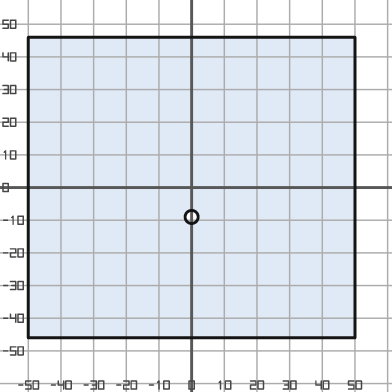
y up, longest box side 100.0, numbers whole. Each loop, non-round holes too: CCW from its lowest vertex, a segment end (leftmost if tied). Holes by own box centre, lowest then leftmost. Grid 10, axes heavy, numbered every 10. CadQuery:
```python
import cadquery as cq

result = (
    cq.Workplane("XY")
    .moveTo(-50.0, -46.0)
    .lineTo(50.0, -46.0)
    .lineTo(50.0, 46.0)
    .lineTo(-50.0, 46.0)
    .close()
    .moveTo(0.0, -9.0)
    .circle(2.0)
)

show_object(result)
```